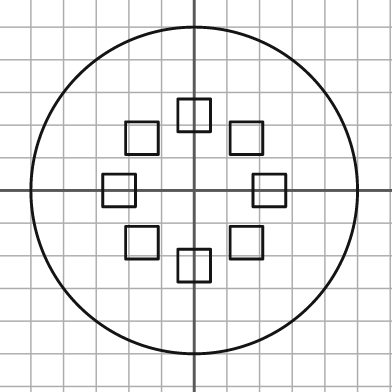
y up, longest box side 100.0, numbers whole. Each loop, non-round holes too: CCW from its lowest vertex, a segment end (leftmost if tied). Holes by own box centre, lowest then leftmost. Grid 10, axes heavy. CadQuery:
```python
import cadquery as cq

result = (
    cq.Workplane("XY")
    .moveTo(0.0, 0.0)
    .circle(50.0)
    .moveTo(-5.0, -28.0)
    .lineTo(5.0, -28.0)
    .lineTo(5.0, -18.0)
    .lineTo(-5.0, -18.0)
    .close()
    .moveTo(-21.0, -21.0)
    .lineTo(-11.0, -21.0)
    .lineTo(-11.0, -11.0)
    .lineTo(-21.0, -11.0)
    .close()
    .moveTo(11.0, -21.0)
    .lineTo(21.0, -21.0)
    .lineTo(21.0, -11.0)
    .lineTo(11.0, -11.0)
    .close()
    .moveTo(-28.0, -5.0)
    .lineTo(-18.0, -5.0)
    .lineTo(-18.0, 5.0)
    .lineTo(-28.0, 5.0)
    .close()
    .moveTo(18.0, -5.0)
    .lineTo(28.0, -5.0)
    .lineTo(28.0, 5.0)
    .lineTo(18.0, 5.0)
    .close()
    .moveTo(-21.0, 11.0)
    .lineTo(-11.0, 11.0)
    .lineTo(-11.0, 21.0)
    .lineTo(-21.0, 21.0)
    .close()
    .moveTo(11.0, 11.0)
    .lineTo(21.0, 11.0)
    .lineTo(21.0, 21.0)
    .lineTo(11.0, 21.0)
    .close()
    .moveTo(-5.0, 18.0)
    .lineTo(5.0, 18.0)
    .lineTo(5.0, 28.0)
    .lineTo(-5.0, 28.0)
    .close()
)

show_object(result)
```